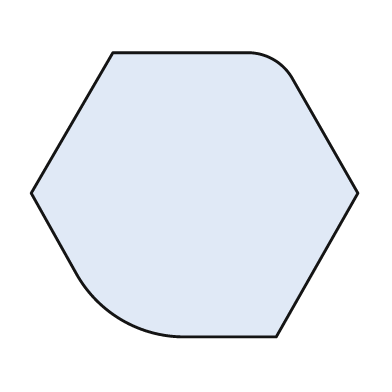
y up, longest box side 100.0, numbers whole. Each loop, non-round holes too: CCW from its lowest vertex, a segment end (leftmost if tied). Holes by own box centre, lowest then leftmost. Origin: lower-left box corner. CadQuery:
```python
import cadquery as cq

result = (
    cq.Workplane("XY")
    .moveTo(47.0, 0.0)
    .lineTo(75.0, 0.0)
    .lineTo(100.0, 44.0)
    .lineTo(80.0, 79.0)
    .threePointArc((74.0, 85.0), (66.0, 87.0))
    .lineTo(25.0, 87.0)
    .lineTo(0.0, 44.0)
    .lineTo(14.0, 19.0)
    .threePointArc((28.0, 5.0), (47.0, 0.0))
    .close()
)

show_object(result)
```